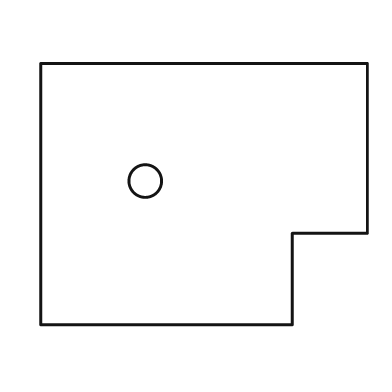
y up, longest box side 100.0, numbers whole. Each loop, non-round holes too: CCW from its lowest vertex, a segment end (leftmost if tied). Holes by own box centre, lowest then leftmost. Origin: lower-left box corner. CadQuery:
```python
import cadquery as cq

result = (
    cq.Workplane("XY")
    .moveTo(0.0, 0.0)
    .lineTo(77.0, 0.0)
    .lineTo(77.0, 28.0)
    .lineTo(100.0, 28.0)
    .lineTo(100.0, 80.0)
    .lineTo(0.0, 80.0)
    .close()
    .moveTo(32.0, 44.0)
    .circle(5.0)
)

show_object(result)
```